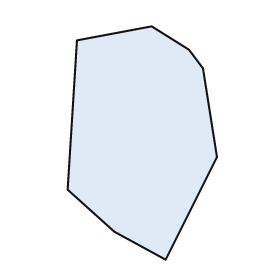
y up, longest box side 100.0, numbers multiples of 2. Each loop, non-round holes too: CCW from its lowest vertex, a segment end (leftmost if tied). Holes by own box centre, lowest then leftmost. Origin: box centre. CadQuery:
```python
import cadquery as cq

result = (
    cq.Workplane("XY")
    .moveTo(10.0, -50.0)
    .lineTo(32.0, -6.0)
    .lineTo(26.0, 32.0)
    .lineTo(20.0, 40.0)
    .lineTo(4.0, 50.0)
    .lineTo(-28.0, 44.0)
    .lineTo(-32.0, -20.0)
    .lineTo(-12.0, -38.0)
    .close()
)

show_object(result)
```